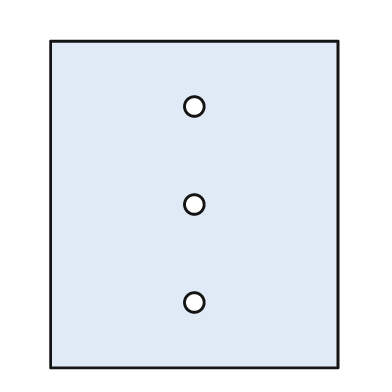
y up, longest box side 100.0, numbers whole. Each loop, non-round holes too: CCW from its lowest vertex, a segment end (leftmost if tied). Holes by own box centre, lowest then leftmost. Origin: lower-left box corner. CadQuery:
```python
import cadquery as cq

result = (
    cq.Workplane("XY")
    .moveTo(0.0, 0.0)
    .lineTo(88.0, 0.0)
    .lineTo(88.0, 100.0)
    .lineTo(0.0, 100.0)
    .close()
    .moveTo(44.0, 20.0)
    .circle(3.0)
    .moveTo(44.0, 50.0)
    .circle(3.0)
    .moveTo(44.0, 80.0)
    .circle(3.0)
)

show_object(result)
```